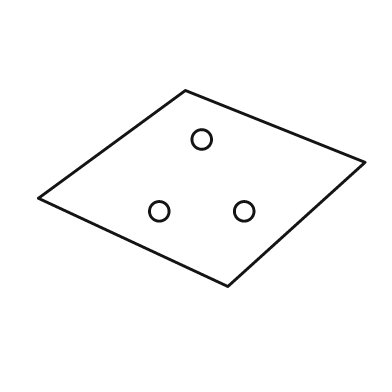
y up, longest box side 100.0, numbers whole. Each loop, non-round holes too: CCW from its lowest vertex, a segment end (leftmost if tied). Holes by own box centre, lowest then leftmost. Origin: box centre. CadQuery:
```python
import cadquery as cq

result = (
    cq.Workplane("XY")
    .moveTo(8.0, -30.0)
    .lineTo(50.0, 8.0)
    .lineTo(-5.0, 30.0)
    .lineTo(-50.0, -3.0)
    .close()
    .moveTo(-13.0, -7.0)
    .circle(3.0)
    .moveTo(13.0, -7.0)
    .circle(3.0)
    .moveTo(0.0, 15.0)
    .circle(3.0)
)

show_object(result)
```